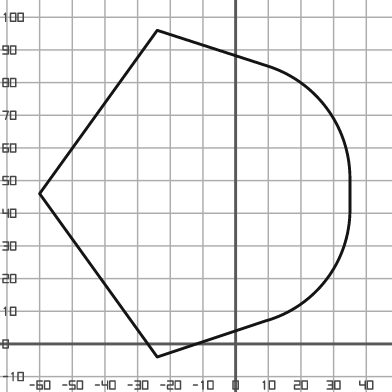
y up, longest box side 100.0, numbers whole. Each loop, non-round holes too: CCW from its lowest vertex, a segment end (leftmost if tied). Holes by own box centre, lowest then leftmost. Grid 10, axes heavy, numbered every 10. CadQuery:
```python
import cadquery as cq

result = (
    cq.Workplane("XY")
    .moveTo(-24.0, -4.0)
    .lineTo(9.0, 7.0)
    .threePointArc((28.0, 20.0), (35.0, 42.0))
    .lineTo(35.0, 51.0)
    .threePointArc((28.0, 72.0), (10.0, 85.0))
    .lineTo(-24.0, 96.0)
    .lineTo(-60.0, 46.0)
    .close()
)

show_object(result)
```